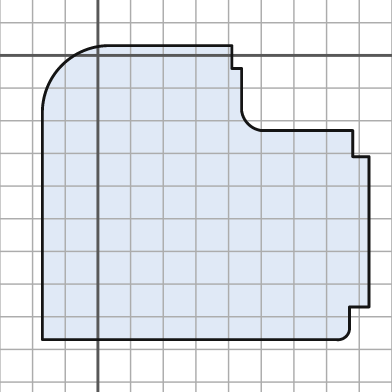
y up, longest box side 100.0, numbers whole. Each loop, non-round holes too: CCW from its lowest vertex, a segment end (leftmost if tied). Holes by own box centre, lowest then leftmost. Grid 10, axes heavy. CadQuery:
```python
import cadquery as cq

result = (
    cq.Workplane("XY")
    .moveTo(-17.0, -87.0)
    .lineTo(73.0, -87.0)
    .threePointArc((76.0, -86.0), (77.0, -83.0))
    .lineTo(77.0, -77.0)
    .lineTo(83.0, -77.0)
    .lineTo(83.0, -31.0)
    .lineTo(78.0, -31.0)
    .lineTo(78.0, -23.0)
    .lineTo(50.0, -23.0)
    .threePointArc((46.0, -21.0), (44.0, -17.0))
    .lineTo(44.0, -4.0)
    .lineTo(41.0, -4.0)
    .lineTo(41.0, 3.0)
    .lineTo(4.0, 3.0)
    .threePointArc((-11.0, -3.0), (-17.0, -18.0))
    .close()
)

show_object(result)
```